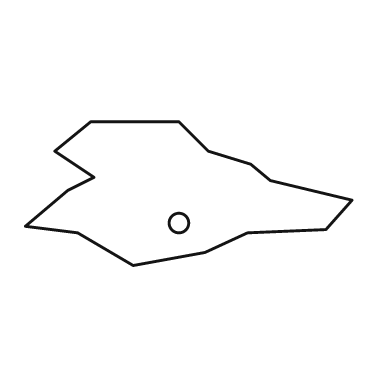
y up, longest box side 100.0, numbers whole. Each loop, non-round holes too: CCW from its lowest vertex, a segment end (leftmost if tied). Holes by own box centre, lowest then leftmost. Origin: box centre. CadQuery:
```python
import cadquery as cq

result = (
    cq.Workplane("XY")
    .moveTo(-17.0, -22.0)
    .lineTo(5.0, -18.0)
    .lineTo(18.0, -12.0)
    .lineTo(42.0, -11.0)
    .lineTo(50.0, -2.0)
    .lineTo(25.0, 4.0)
    .lineTo(19.0, 9.0)
    .lineTo(6.0, 13.0)
    .lineTo(-3.0, 22.0)
    .lineTo(-30.0, 22.0)
    .lineTo(-41.0, 13.0)
    .lineTo(-29.0, 5.0)
    .lineTo(-37.0, 1.0)
    .lineTo(-50.0, -10.0)
    .lineTo(-34.0, -12.0)
    .close()
    .moveTo(-3.0, -9.0)
    .circle(3.0)
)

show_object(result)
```